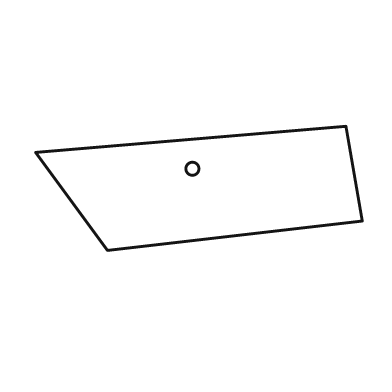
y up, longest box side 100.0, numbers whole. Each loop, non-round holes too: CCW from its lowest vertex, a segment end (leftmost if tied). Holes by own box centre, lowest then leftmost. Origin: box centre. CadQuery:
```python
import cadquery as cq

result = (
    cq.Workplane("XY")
    .moveTo(-28.0, -19.0)
    .lineTo(50.0, -10.0)
    .lineTo(45.0, 19.0)
    .lineTo(-50.0, 11.0)
    .close()
    .moveTo(-2.0, 6.0)
    .circle(2.0)
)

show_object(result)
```